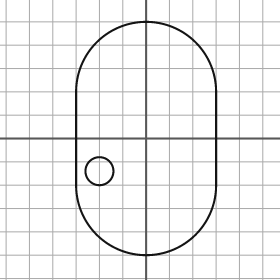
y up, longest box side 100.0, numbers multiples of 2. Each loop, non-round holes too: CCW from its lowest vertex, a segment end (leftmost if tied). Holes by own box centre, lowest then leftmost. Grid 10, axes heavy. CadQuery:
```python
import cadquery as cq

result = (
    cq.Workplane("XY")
    .moveTo(-30.0, -20.0)
    .threePointArc((0.0, -50.0), (30.0, -20.0))
    .lineTo(30.0, 20.0)
    .threePointArc((0.0, 50.0), (-30.0, 20.0))
    .close()
    .moveTo(-20.0, -14.0)
    .circle(6.0)
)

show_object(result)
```